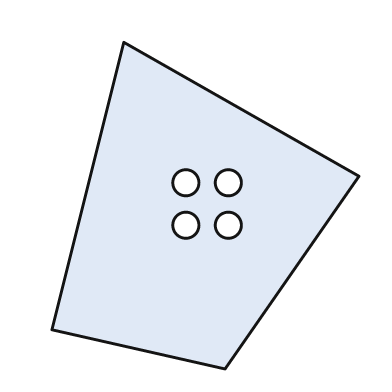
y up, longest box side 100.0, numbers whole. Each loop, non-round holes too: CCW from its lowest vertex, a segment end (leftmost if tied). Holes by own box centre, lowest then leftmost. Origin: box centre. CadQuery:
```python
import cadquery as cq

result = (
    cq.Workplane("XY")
    .moveTo(6.0, -50.0)
    .lineTo(47.0, 9.0)
    .lineTo(-25.0, 50.0)
    .lineTo(-47.0, -38.0)
    .close()
    .moveTo(-6.0, -6.0)
    .circle(4.0)
    .moveTo(7.0, -6.0)
    .circle(4.0)
    .moveTo(-6.0, 7.0)
    .circle(4.0)
    .moveTo(7.0, 7.0)
    .circle(4.0)
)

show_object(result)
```